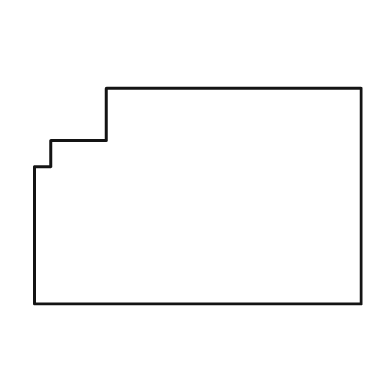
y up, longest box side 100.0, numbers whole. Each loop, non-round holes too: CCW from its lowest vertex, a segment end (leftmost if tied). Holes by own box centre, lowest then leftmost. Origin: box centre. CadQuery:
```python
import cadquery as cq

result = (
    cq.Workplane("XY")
    .moveTo(-50.0, -33.0)
    .lineTo(50.0, -33.0)
    .lineTo(50.0, 33.0)
    .lineTo(-28.0, 33.0)
    .lineTo(-28.0, 17.0)
    .lineTo(-45.0, 17.0)
    .lineTo(-45.0, 9.0)
    .lineTo(-50.0, 9.0)
    .close()
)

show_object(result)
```